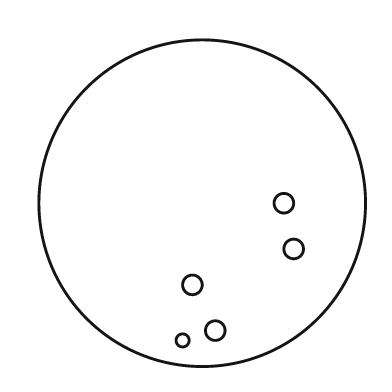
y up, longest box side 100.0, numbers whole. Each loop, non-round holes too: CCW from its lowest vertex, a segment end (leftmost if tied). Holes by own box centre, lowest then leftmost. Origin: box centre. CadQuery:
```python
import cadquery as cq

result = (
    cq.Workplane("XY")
    .moveTo(0.0, 0.0)
    .circle(50.0)
    .moveTo(-6.0, -42.0)
    .circle(2.0)
    .moveTo(4.0, -39.0)
    .circle(3.0)
    .moveTo(-3.0, -25.0)
    .circle(3.0)
    .moveTo(28.0, -14.0)
    .circle(3.0)
    .moveTo(25.0, 0.0)
    .circle(3.0)
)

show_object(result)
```